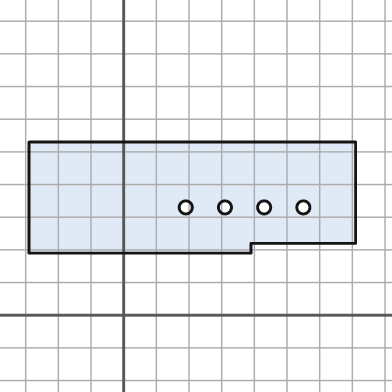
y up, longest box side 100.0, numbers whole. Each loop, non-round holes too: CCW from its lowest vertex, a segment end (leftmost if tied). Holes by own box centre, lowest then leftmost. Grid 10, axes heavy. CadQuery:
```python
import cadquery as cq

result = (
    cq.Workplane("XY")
    .moveTo(-29.0, 19.0)
    .lineTo(39.0, 19.0)
    .lineTo(39.0, 22.0)
    .lineTo(71.0, 22.0)
    .lineTo(71.0, 53.0)
    .lineTo(-29.0, 53.0)
    .close()
    .moveTo(19.0, 33.0)
    .circle(2.0)
    .moveTo(31.0, 33.0)
    .circle(2.0)
    .moveTo(43.0, 33.0)
    .circle(2.0)
    .moveTo(55.0, 33.0)
    .circle(2.0)
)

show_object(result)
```